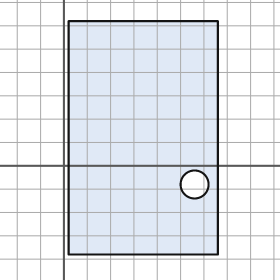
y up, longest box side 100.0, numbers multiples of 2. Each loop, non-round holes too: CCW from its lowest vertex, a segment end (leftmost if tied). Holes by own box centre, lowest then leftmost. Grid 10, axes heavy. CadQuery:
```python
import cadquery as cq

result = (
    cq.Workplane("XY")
    .moveTo(2.0, -38.0)
    .lineTo(66.0, -38.0)
    .lineTo(66.0, 62.0)
    .lineTo(2.0, 62.0)
    .close()
    .moveTo(56.0, -8.0)
    .circle(6.0)
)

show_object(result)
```